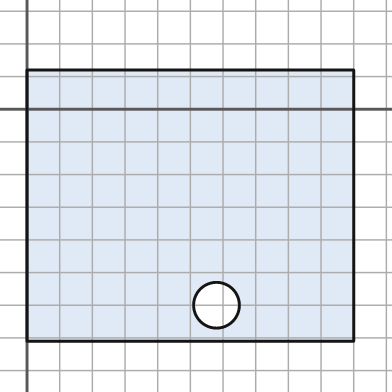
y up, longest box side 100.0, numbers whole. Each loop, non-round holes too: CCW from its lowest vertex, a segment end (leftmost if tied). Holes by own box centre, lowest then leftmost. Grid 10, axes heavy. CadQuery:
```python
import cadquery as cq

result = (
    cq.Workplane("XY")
    .moveTo(0.0, -71.0)
    .lineTo(100.0, -71.0)
    .lineTo(100.0, 12.0)
    .lineTo(0.0, 12.0)
    .close()
    .moveTo(58.0, -60.0)
    .circle(7.0)
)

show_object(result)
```